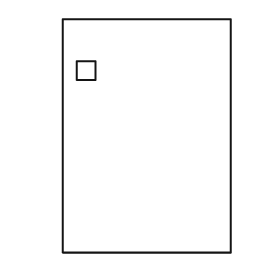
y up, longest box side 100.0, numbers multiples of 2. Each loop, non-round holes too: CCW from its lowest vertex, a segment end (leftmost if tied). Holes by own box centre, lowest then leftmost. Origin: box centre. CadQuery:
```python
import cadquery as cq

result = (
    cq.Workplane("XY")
    .moveTo(-36.0, -50.0)
    .lineTo(36.0, -50.0)
    .lineTo(36.0, 50.0)
    .lineTo(-36.0, 50.0)
    .close()
    .moveTo(-30.0, 24.0)
    .lineTo(-22.0, 24.0)
    .lineTo(-22.0, 32.0)
    .lineTo(-30.0, 32.0)
    .close()
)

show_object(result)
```